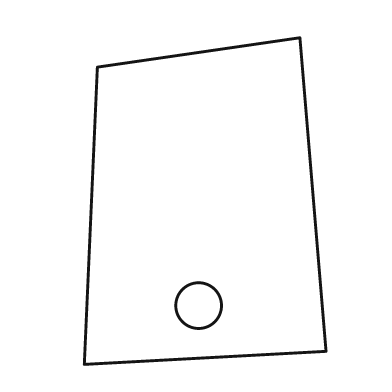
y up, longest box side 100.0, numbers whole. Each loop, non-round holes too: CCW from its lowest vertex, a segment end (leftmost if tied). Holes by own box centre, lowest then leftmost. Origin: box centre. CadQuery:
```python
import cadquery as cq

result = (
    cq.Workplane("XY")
    .moveTo(-37.0, -50.0)
    .lineTo(37.0, -46.0)
    .lineTo(29.0, 50.0)
    .lineTo(-33.0, 41.0)
    .close()
    .moveTo(-2.0, -32.0)
    .circle(7.0)
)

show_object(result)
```